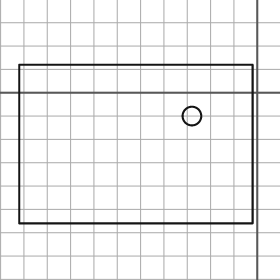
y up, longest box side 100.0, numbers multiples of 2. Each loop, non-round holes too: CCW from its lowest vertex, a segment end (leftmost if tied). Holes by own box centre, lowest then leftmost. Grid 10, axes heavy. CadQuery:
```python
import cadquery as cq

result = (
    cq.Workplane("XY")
    .moveTo(-102.0, -56.0)
    .lineTo(-2.0, -56.0)
    .lineTo(-2.0, 12.0)
    .lineTo(-102.0, 12.0)
    .close()
    .moveTo(-28.0, -10.0)
    .circle(4.0)
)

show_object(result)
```